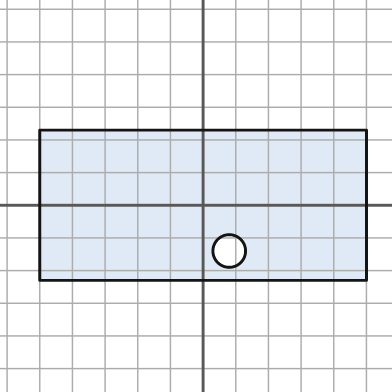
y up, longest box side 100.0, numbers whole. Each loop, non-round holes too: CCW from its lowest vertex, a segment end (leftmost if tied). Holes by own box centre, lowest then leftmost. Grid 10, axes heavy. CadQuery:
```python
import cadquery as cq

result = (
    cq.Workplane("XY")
    .moveTo(-50.0, -23.0)
    .lineTo(50.0, -23.0)
    .lineTo(50.0, 23.0)
    .lineTo(-50.0, 23.0)
    .close()
    .moveTo(8.0, -14.0)
    .circle(5.0)
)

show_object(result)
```